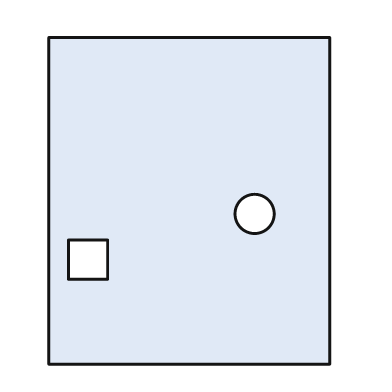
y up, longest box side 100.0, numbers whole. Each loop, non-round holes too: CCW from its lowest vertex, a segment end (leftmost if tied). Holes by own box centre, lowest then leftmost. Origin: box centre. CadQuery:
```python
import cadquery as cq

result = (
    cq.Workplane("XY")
    .moveTo(-43.0, -50.0)
    .lineTo(43.0, -50.0)
    .lineTo(43.0, 50.0)
    .lineTo(-43.0, 50.0)
    .close()
    .moveTo(-37.0, -24.0)
    .lineTo(-25.0, -24.0)
    .lineTo(-25.0, -12.0)
    .lineTo(-37.0, -12.0)
    .close()
    .moveTo(20.0, -4.0)
    .circle(6.0)
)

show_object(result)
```